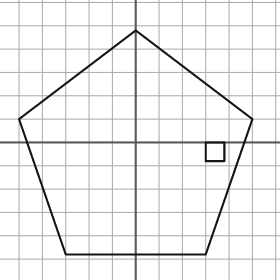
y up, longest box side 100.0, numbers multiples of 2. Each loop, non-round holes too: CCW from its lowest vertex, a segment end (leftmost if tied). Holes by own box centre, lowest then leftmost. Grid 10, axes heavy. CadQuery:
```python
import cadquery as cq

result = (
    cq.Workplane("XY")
    .moveTo(-30.0, -48.0)
    .lineTo(30.0, -48.0)
    .lineTo(50.0, 10.0)
    .lineTo(0.0, 48.0)
    .lineTo(-50.0, 10.0)
    .close()
    .moveTo(30.0, -8.0)
    .lineTo(38.0, -8.0)
    .lineTo(38.0, 0.0)
    .lineTo(30.0, 0.0)
    .close()
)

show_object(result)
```